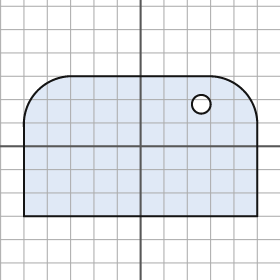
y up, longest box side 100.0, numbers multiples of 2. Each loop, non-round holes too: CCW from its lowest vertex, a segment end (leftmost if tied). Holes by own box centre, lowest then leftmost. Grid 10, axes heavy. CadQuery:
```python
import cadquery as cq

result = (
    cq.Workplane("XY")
    .moveTo(-50.0, -30.0)
    .lineTo(50.0, -30.0)
    .lineTo(50.0, 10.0)
    .threePointArc((44.0, 24.0), (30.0, 30.0))
    .lineTo(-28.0, 30.0)
    .threePointArc((-44.0, 24.0), (-50.0, 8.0))
    .close()
    .moveTo(26.0, 18.0)
    .circle(4.0)
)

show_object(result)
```